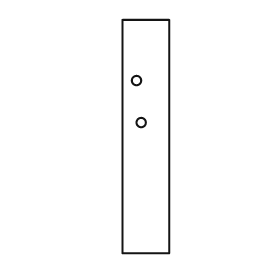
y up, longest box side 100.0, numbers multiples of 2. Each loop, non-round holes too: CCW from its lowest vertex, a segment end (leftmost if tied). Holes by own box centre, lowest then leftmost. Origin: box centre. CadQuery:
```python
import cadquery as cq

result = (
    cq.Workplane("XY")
    .moveTo(-10.0, -50.0)
    .lineTo(10.0, -50.0)
    .lineTo(10.0, 50.0)
    .lineTo(-10.0, 50.0)
    .close()
    .moveTo(-2.0, 6.0)
    .circle(2.0)
    .moveTo(-4.0, 24.0)
    .circle(2.0)
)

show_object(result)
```